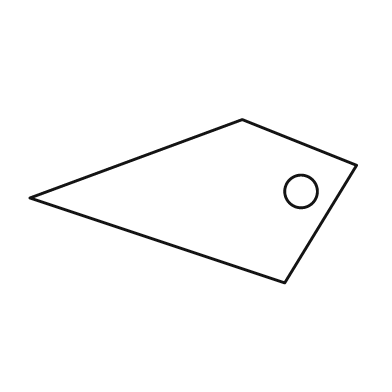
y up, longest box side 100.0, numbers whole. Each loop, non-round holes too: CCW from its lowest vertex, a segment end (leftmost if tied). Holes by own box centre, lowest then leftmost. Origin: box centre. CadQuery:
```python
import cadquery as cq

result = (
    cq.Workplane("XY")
    .moveTo(28.0, -25.0)
    .lineTo(50.0, 11.0)
    .lineTo(15.0, 25.0)
    .lineTo(-50.0, 1.0)
    .close()
    .moveTo(33.0, 3.0)
    .circle(5.0)
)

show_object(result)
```